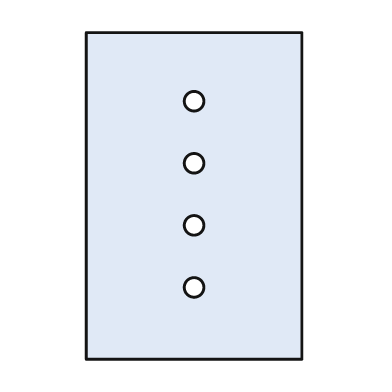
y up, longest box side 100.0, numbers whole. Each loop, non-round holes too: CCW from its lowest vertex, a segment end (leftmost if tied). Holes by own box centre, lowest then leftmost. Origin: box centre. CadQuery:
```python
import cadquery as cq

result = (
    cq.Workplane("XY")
    .moveTo(-33.0, -50.0)
    .lineTo(33.0, -50.0)
    .lineTo(33.0, 50.0)
    .lineTo(-33.0, 50.0)
    .close()
    .moveTo(0.0, -28.0)
    .circle(3.0)
    .moveTo(0.0, -9.0)
    .circle(3.0)
    .moveTo(0.0, 10.0)
    .circle(3.0)
    .moveTo(0.0, 29.0)
    .circle(3.0)
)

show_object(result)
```